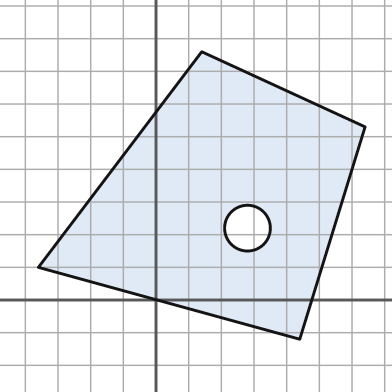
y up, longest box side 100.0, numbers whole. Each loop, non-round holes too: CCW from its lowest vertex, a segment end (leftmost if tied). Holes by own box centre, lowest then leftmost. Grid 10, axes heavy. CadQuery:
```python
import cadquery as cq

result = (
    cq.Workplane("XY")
    .moveTo(44.0, -12.0)
    .lineTo(64.0, 53.0)
    .lineTo(14.0, 76.0)
    .lineTo(-36.0, 10.0)
    .close()
    .moveTo(28.0, 22.0)
    .circle(7.0)
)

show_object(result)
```